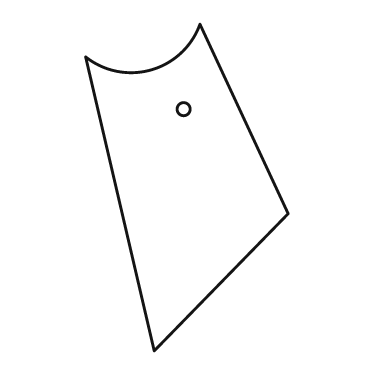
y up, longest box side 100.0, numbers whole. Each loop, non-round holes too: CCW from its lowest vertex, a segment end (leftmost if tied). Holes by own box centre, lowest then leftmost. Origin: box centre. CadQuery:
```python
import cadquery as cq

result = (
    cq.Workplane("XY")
    .moveTo(-10.0, -50.0)
    .lineTo(31.0, -8.0)
    .lineTo(4.0, 50.0)
    .threePointArc((-11.0, 36.0), (-31.0, 40.0))
    .close()
    .moveTo(-1.0, 24.0)
    .circle(2.0)
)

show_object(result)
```